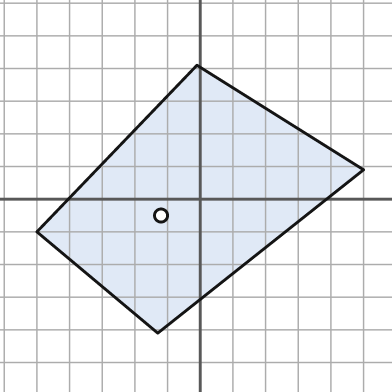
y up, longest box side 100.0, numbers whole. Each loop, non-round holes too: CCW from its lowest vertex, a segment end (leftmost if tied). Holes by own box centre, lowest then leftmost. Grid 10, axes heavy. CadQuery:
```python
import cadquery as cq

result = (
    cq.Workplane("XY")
    .moveTo(-13.0, -41.0)
    .lineTo(50.0, 9.0)
    .lineTo(-1.0, 41.0)
    .lineTo(-50.0, -10.0)
    .close()
    .moveTo(-12.0, -5.0)
    .circle(2.0)
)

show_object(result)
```